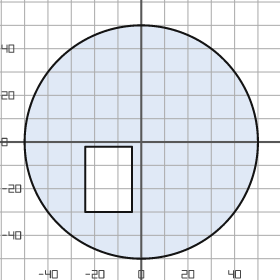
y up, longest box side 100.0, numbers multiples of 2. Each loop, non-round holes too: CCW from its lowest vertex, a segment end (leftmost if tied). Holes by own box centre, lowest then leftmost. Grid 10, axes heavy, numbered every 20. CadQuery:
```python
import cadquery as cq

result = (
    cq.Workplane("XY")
    .moveTo(0.0, 0.0)
    .circle(50.0)
    .moveTo(-24.0, -30.0)
    .lineTo(-4.0, -30.0)
    .lineTo(-4.0, -2.0)
    .lineTo(-24.0, -2.0)
    .close()
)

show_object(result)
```